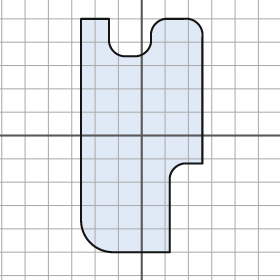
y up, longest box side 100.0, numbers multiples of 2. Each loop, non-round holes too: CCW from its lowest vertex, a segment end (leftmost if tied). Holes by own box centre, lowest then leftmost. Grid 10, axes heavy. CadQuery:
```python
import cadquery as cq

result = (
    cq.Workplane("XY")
    .moveTo(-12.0, -50.0)
    .lineTo(12.0, -50.0)
    .lineTo(12.0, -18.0)
    .threePointArc((14.0, -14.0), (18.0, -12.0))
    .lineTo(26.0, -12.0)
    .lineTo(26.0, 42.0)
    .threePointArc((24.0, 48.0), (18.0, 50.0))
    .lineTo(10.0, 50.0)
    .threePointArc((6.0, 48.0), (4.0, 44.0))
    .lineTo(4.0, 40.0)
    .threePointArc((2.0, 36.0), (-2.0, 34.0))
    .lineTo(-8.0, 34.0)
    .threePointArc((-12.0, 36.0), (-14.0, 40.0))
    .lineTo(-14.0, 50.0)
    .lineTo(-26.0, 50.0)
    .lineTo(-26.0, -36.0)
    .threePointArc((-22.0, -46.0), (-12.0, -50.0))
    .close()
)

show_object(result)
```